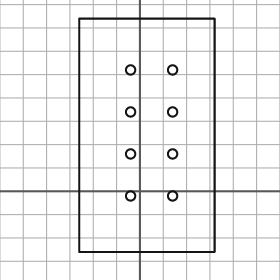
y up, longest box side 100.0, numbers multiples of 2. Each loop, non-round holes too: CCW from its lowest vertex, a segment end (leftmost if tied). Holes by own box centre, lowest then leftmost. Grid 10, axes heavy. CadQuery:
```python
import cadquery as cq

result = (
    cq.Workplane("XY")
    .moveTo(-26.0, -26.0)
    .lineTo(32.0, -26.0)
    .lineTo(32.0, 74.0)
    .lineTo(-26.0, 74.0)
    .close()
    .moveTo(-4.0, -2.0)
    .circle(2.0)
    .moveTo(14.0, -2.0)
    .circle(2.0)
    .moveTo(-4.0, 16.0)
    .circle(2.0)
    .moveTo(14.0, 16.0)
    .circle(2.0)
    .moveTo(-4.0, 34.0)
    .circle(2.0)
    .moveTo(14.0, 34.0)
    .circle(2.0)
    .moveTo(-4.0, 52.0)
    .circle(2.0)
    .moveTo(14.0, 52.0)
    .circle(2.0)
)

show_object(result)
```